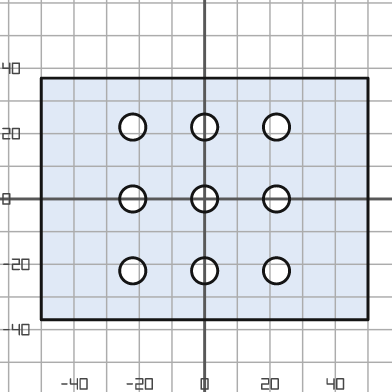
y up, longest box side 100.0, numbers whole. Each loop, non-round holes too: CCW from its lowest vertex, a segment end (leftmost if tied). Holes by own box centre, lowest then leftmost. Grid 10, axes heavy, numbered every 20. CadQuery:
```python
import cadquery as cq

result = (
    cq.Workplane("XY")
    .moveTo(-50.0, -37.0)
    .lineTo(50.0, -37.0)
    .lineTo(50.0, 37.0)
    .lineTo(-50.0, 37.0)
    .close()
    .moveTo(-22.0, -22.0)
    .circle(4.0)
    .moveTo(0.0, -22.0)
    .circle(4.0)
    .moveTo(22.0, -22.0)
    .circle(4.0)
    .moveTo(-22.0, 0.0)
    .circle(4.0)
    .moveTo(0.0, 0.0)
    .circle(4.0)
    .moveTo(22.0, 0.0)
    .circle(4.0)
    .moveTo(-22.0, 22.0)
    .circle(4.0)
    .moveTo(0.0, 22.0)
    .circle(4.0)
    .moveTo(22.0, 22.0)
    .circle(4.0)
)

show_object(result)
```